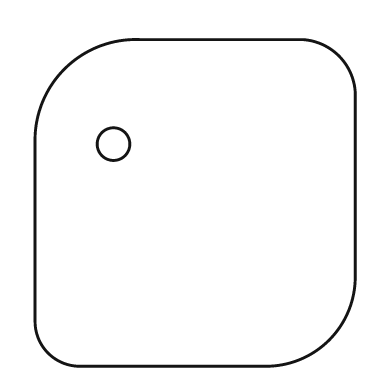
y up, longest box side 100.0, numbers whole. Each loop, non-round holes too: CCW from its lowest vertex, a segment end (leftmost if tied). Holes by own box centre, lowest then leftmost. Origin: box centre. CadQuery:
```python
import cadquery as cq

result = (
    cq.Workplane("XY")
    .moveTo(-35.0, -50.0)
    .lineTo(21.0, -50.0)
    .threePointArc((41.0, -42.0), (49.0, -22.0))
    .lineTo(49.0, 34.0)
    .threePointArc((44.0, 45.0), (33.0, 50.0))
    .lineTo(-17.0, 50.0)
    .threePointArc((-40.0, 41.0), (-49.0, 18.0))
    .lineTo(-49.0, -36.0)
    .threePointArc((-45.0, -46.0), (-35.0, -50.0))
    .close()
    .moveTo(-25.0, 18.0)
    .circle(5.0)
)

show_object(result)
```